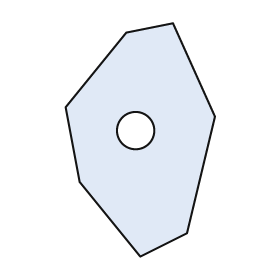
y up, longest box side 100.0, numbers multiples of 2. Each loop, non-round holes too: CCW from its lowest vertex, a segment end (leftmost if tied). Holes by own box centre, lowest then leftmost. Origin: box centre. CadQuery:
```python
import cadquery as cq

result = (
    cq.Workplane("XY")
    .moveTo(0.0, -50.0)
    .lineTo(20.0, -40.0)
    .lineTo(32.0, 10.0)
    .lineTo(14.0, 50.0)
    .lineTo(-6.0, 46.0)
    .lineTo(-32.0, 14.0)
    .lineTo(-26.0, -18.0)
    .close()
    .moveTo(-2.0, 4.0)
    .circle(8.0)
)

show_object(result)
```